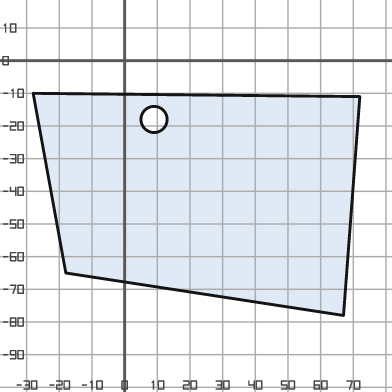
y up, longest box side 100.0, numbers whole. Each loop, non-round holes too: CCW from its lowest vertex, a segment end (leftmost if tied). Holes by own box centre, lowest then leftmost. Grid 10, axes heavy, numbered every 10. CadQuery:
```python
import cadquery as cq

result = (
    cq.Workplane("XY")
    .moveTo(67.0, -78.0)
    .lineTo(72.0, -11.0)
    .lineTo(-28.0, -10.0)
    .lineTo(-18.0, -65.0)
    .close()
    .moveTo(9.0, -18.0)
    .circle(4.0)
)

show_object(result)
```